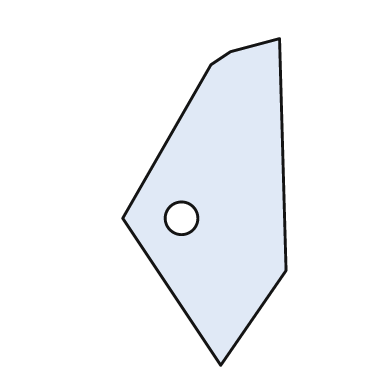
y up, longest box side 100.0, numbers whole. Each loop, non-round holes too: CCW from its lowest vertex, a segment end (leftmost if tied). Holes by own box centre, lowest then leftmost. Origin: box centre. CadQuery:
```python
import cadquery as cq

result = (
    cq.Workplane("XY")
    .moveTo(5.0, -50.0)
    .lineTo(25.0, -21.0)
    .lineTo(23.0, 50.0)
    .lineTo(8.0, 46.0)
    .lineTo(2.0, 42.0)
    .lineTo(-25.0, -5.0)
    .close()
    .moveTo(-7.0, -5.0)
    .circle(5.0)
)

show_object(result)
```